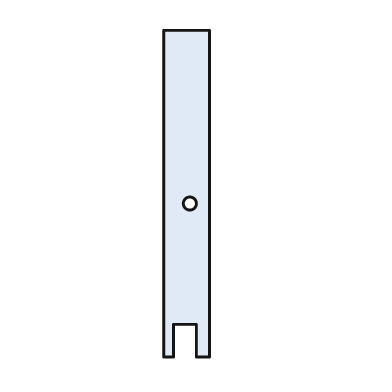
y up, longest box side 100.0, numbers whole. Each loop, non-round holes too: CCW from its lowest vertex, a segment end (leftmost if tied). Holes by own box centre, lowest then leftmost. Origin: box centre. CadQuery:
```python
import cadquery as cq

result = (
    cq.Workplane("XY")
    .moveTo(-7.0, -50.0)
    .lineTo(-4.0, -50.0)
    .lineTo(-4.0, -40.0)
    .lineTo(3.0, -40.0)
    .lineTo(3.0, -50.0)
    .lineTo(7.0, -50.0)
    .lineTo(7.0, 50.0)
    .lineTo(-7.0, 50.0)
    .close()
    .moveTo(1.0, -3.0)
    .circle(2.0)
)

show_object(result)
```